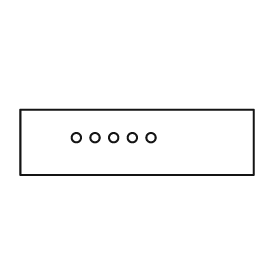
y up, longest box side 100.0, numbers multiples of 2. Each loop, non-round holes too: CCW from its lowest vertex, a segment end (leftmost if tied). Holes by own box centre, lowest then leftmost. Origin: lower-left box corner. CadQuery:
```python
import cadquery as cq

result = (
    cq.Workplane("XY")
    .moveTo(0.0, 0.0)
    .lineTo(100.0, 0.0)
    .lineTo(100.0, 28.0)
    .lineTo(0.0, 28.0)
    .close()
    .moveTo(24.0, 16.0)
    .circle(2.0)
    .moveTo(32.0, 16.0)
    .circle(2.0)
    .moveTo(40.0, 16.0)
    .circle(2.0)
    .moveTo(48.0, 16.0)
    .circle(2.0)
    .moveTo(56.0, 16.0)
    .circle(2.0)
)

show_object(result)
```